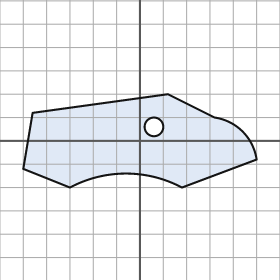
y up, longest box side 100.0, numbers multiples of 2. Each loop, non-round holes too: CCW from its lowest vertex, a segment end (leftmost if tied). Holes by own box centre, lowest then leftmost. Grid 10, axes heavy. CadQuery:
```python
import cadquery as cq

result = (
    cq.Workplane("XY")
    .moveTo(-30.0, -20.0)
    .threePointArc((-6.0, -14.0), (18.0, -20.0))
    .lineTo(50.0, -8.0)
    .threePointArc((44.0, 4.0), (32.0, 10.0))
    .lineTo(12.0, 20.0)
    .lineTo(-46.0, 12.0)
    .lineTo(-50.0, -12.0)
    .close()
    .moveTo(6.0, 6.0)
    .circle(4.0)
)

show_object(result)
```